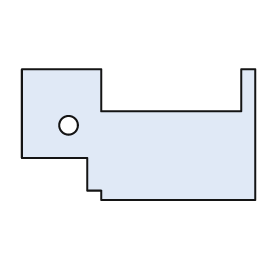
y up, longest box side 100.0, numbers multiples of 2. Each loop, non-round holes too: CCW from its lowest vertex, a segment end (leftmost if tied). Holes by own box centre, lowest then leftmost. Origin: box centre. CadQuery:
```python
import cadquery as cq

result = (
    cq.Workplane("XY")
    .moveTo(-16.0, -28.0)
    .lineTo(50.0, -28.0)
    .lineTo(50.0, 28.0)
    .lineTo(44.0, 28.0)
    .lineTo(44.0, 10.0)
    .lineTo(-16.0, 10.0)
    .lineTo(-16.0, 28.0)
    .lineTo(-50.0, 28.0)
    .lineTo(-50.0, -10.0)
    .lineTo(-22.0, -10.0)
    .lineTo(-22.0, -24.0)
    .lineTo(-16.0, -24.0)
    .close()
    .moveTo(-30.0, 4.0)
    .circle(4.0)
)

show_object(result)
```